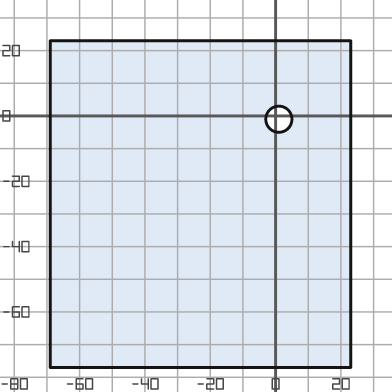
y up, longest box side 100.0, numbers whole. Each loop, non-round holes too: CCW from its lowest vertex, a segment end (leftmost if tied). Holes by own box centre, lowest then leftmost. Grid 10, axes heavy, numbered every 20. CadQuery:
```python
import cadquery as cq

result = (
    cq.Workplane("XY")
    .moveTo(-69.0, -77.0)
    .lineTo(23.0, -77.0)
    .lineTo(23.0, 23.0)
    .lineTo(-69.0, 23.0)
    .close()
    .moveTo(1.0, -1.0)
    .circle(4.0)
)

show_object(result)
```